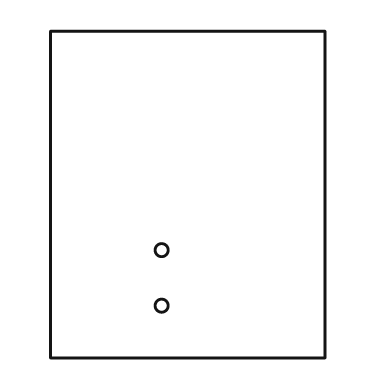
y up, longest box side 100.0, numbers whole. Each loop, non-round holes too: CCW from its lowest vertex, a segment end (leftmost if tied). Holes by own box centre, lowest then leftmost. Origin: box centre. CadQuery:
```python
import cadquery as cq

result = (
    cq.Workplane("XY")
    .moveTo(-42.0, -50.0)
    .lineTo(42.0, -50.0)
    .lineTo(42.0, 50.0)
    .lineTo(-42.0, 50.0)
    .close()
    .moveTo(-8.0, -34.0)
    .circle(2.0)
    .moveTo(-8.0, -17.0)
    .circle(2.0)
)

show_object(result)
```